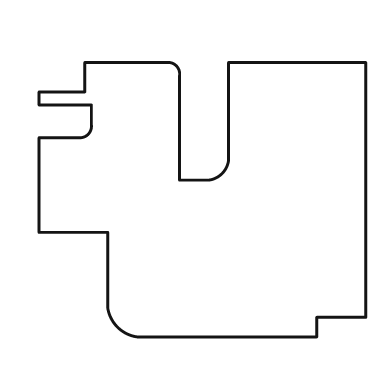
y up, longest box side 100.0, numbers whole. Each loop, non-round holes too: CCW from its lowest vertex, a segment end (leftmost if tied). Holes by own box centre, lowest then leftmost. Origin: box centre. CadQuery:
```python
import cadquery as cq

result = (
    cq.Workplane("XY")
    .moveTo(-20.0, -42.0)
    .lineTo(35.0, -42.0)
    .lineTo(35.0, -36.0)
    .lineTo(50.0, -36.0)
    .lineTo(50.0, 42.0)
    .lineTo(8.0, 42.0)
    .lineTo(8.0, 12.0)
    .threePointArc((6.0, 8.0), (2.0, 6.0))
    .lineTo(-7.0, 6.0)
    .lineTo(-7.0, 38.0)
    .threePointArc((-8.0, 41.0), (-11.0, 42.0))
    .lineTo(-36.0, 42.0)
    .lineTo(-36.0, 33.0)
    .lineTo(-50.0, 33.0)
    .lineTo(-50.0, 29.0)
    .lineTo(-34.0, 29.0)
    .lineTo(-34.0, 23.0)
    .threePointArc((-35.0, 20.0), (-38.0, 19.0))
    .lineTo(-50.0, 19.0)
    .lineTo(-50.0, -10.0)
    .lineTo(-29.0, -10.0)
    .lineTo(-29.0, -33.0)
    .threePointArc((-26.0, -39.0), (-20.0, -42.0))
    .close()
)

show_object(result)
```